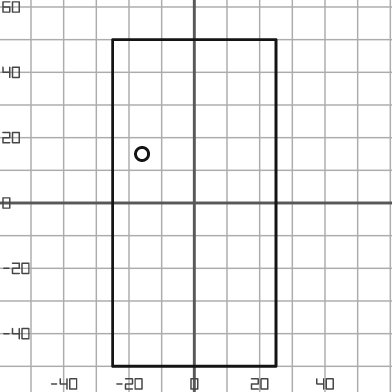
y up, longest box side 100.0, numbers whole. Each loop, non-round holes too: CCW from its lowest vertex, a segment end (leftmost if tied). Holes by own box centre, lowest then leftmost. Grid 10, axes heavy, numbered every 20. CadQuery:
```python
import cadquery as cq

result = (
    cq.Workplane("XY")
    .moveTo(-25.0, -50.0)
    .lineTo(25.0, -50.0)
    .lineTo(25.0, 50.0)
    .lineTo(-25.0, 50.0)
    .close()
    .moveTo(-16.0, 15.0)
    .circle(2.0)
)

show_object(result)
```